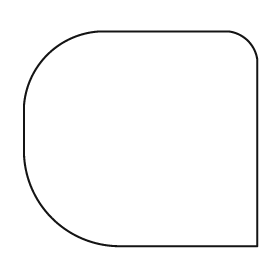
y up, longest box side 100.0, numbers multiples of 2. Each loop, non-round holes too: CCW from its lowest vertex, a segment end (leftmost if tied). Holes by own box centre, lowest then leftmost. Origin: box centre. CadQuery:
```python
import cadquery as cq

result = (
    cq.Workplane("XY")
    .moveTo(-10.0, -46.0)
    .lineTo(50.0, -46.0)
    .lineTo(50.0, 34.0)
    .threePointArc((46.0, 42.0), (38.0, 46.0))
    .lineTo(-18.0, 46.0)
    .threePointArc((-40.0, 36.0), (-50.0, 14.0))
    .lineTo(-50.0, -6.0)
    .threePointArc((-38.0, -34.0), (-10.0, -46.0))
    .close()
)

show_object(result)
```